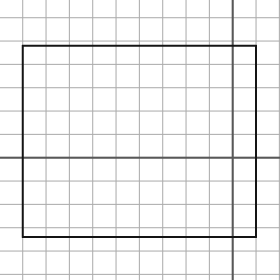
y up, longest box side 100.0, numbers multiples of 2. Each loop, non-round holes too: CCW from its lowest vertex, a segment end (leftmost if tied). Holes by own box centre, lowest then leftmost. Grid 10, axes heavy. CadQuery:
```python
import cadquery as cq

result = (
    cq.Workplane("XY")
    .moveTo(-90.0, -34.0)
    .lineTo(10.0, -34.0)
    .lineTo(10.0, 48.0)
    .lineTo(-90.0, 48.0)
    .close()
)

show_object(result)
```